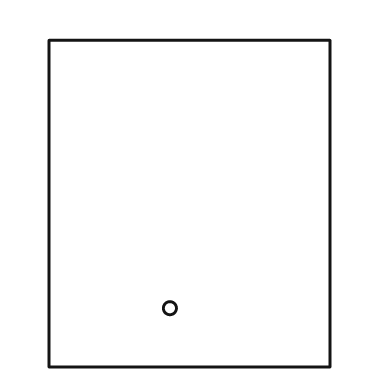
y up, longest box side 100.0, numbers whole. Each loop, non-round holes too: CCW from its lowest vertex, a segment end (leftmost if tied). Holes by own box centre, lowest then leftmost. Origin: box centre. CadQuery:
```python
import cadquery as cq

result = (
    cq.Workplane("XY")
    .moveTo(-43.0, -50.0)
    .lineTo(43.0, -50.0)
    .lineTo(43.0, 50.0)
    .lineTo(-43.0, 50.0)
    .close()
    .moveTo(-6.0, -32.0)
    .circle(2.0)
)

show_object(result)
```